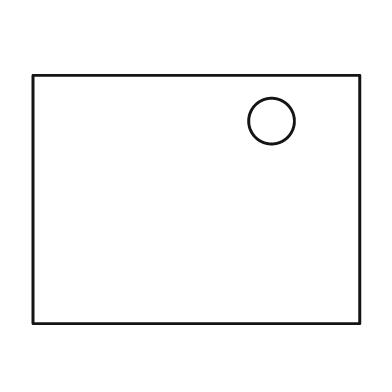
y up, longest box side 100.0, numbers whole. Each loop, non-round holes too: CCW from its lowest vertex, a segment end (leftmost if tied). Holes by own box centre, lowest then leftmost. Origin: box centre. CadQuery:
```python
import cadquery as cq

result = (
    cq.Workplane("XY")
    .moveTo(-50.0, -38.0)
    .lineTo(50.0, -38.0)
    .lineTo(50.0, 38.0)
    .lineTo(-50.0, 38.0)
    .close()
    .moveTo(23.0, 24.0)
    .circle(7.0)
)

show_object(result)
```